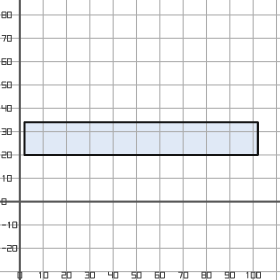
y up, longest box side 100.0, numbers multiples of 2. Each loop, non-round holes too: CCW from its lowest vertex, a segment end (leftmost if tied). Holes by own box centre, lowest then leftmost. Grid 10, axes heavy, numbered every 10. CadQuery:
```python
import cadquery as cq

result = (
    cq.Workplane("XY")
    .moveTo(2.0, 20.0)
    .lineTo(102.0, 20.0)
    .lineTo(102.0, 34.0)
    .lineTo(2.0, 34.0)
    .close()
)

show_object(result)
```